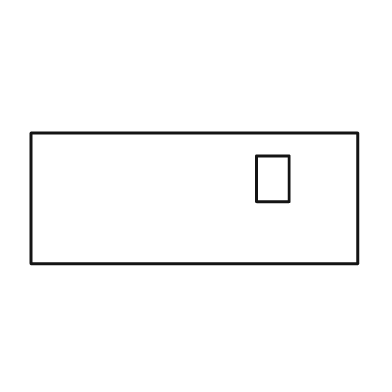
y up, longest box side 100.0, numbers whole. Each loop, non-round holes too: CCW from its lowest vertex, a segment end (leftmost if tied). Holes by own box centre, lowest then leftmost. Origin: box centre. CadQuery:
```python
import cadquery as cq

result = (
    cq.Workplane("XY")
    .moveTo(-50.0, -20.0)
    .lineTo(50.0, -20.0)
    .lineTo(50.0, 20.0)
    .lineTo(-50.0, 20.0)
    .close()
    .moveTo(19.0, -1.0)
    .lineTo(29.0, -1.0)
    .lineTo(29.0, 13.0)
    .lineTo(19.0, 13.0)
    .close()
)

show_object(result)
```